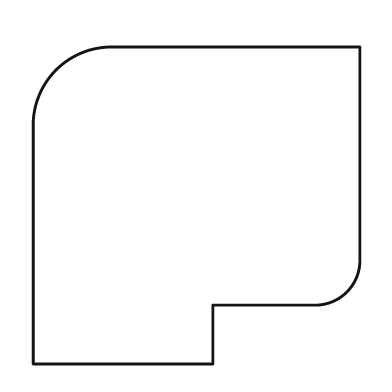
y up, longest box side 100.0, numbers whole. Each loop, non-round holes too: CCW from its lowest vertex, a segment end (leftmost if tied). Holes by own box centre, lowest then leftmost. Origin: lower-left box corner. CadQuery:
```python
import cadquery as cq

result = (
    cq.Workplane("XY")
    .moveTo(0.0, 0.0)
    .lineTo(55.0, 0.0)
    .lineTo(55.0, 18.0)
    .lineTo(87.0, 18.0)
    .threePointArc((96.0, 22.0), (100.0, 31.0))
    .lineTo(100.0, 97.0)
    .lineTo(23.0, 97.0)
    .threePointArc((7.0, 90.0), (0.0, 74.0))
    .close()
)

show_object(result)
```